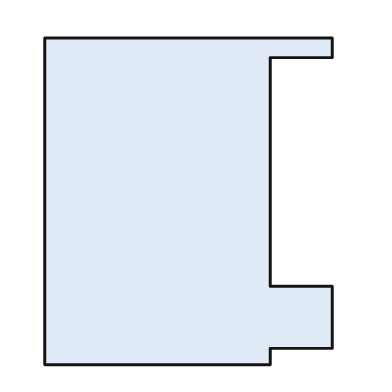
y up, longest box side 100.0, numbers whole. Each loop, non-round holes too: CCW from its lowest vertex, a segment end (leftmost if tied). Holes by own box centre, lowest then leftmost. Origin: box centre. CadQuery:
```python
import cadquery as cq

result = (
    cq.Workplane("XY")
    .moveTo(-44.0, -50.0)
    .lineTo(25.0, -50.0)
    .lineTo(25.0, -45.0)
    .lineTo(44.0, -45.0)
    .lineTo(44.0, -26.0)
    .lineTo(25.0, -26.0)
    .lineTo(25.0, 44.0)
    .lineTo(44.0, 44.0)
    .lineTo(44.0, 50.0)
    .lineTo(-44.0, 50.0)
    .close()
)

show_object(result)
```